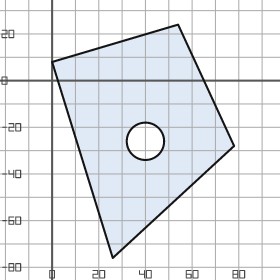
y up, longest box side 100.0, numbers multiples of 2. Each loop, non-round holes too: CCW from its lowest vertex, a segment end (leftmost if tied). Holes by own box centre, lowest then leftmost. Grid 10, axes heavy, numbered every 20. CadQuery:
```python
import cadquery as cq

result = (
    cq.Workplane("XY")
    .moveTo(26.0, -76.0)
    .lineTo(78.0, -28.0)
    .lineTo(54.0, 24.0)
    .lineTo(0.0, 8.0)
    .close()
    .moveTo(40.0, -26.0)
    .circle(8.0)
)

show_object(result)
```